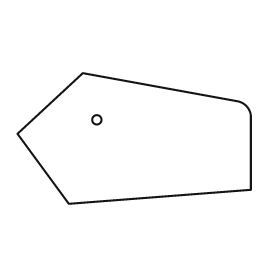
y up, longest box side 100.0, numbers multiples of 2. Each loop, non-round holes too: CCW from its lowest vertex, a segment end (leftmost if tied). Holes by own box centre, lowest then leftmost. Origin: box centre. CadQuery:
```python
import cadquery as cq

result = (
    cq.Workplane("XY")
    .moveTo(-28.0, -28.0)
    .lineTo(50.0, -22.0)
    .lineTo(50.0, 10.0)
    .threePointArc((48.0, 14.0), (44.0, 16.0))
    .lineTo(-22.0, 28.0)
    .lineTo(-50.0, 2.0)
    .close()
    .moveTo(-16.0, 8.0)
    .circle(2.0)
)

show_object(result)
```